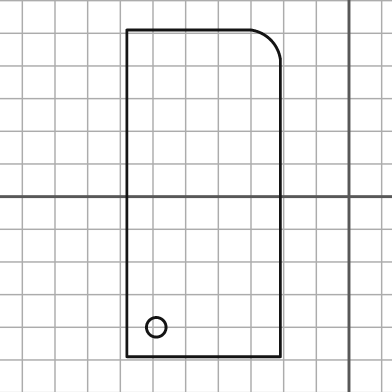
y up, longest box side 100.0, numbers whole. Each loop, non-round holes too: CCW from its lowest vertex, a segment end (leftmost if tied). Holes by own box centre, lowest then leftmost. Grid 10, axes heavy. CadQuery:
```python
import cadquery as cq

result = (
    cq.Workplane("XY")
    .moveTo(-68.0, -49.0)
    .lineTo(-21.0, -49.0)
    .lineTo(-21.0, 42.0)
    .threePointArc((-24.0, 48.0), (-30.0, 51.0))
    .lineTo(-68.0, 51.0)
    .close()
    .moveTo(-59.0, -40.0)
    .circle(3.0)
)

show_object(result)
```